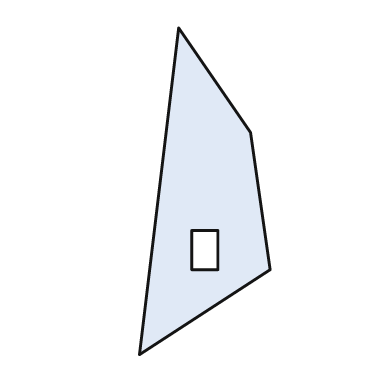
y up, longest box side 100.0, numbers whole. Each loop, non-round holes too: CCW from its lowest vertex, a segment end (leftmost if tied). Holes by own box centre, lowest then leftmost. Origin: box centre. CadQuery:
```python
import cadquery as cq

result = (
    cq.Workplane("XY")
    .moveTo(-20.0, -50.0)
    .lineTo(20.0, -24.0)
    .lineTo(14.0, 18.0)
    .lineTo(-8.0, 50.0)
    .close()
    .moveTo(-4.0, -24.0)
    .lineTo(4.0, -24.0)
    .lineTo(4.0, -12.0)
    .lineTo(-4.0, -12.0)
    .close()
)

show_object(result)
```